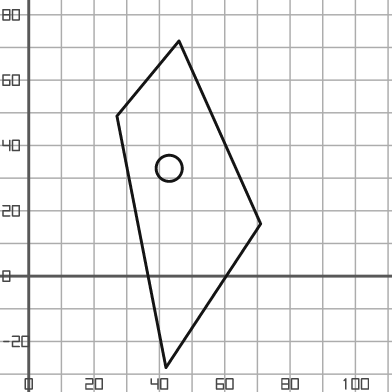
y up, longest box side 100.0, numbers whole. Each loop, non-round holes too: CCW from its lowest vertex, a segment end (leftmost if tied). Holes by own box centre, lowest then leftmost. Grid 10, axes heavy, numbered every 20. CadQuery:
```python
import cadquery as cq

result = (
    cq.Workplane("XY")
    .moveTo(42.0, -28.0)
    .lineTo(71.0, 16.0)
    .lineTo(46.0, 72.0)
    .lineTo(27.0, 49.0)
    .close()
    .moveTo(43.0, 33.0)
    .circle(4.0)
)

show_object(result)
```